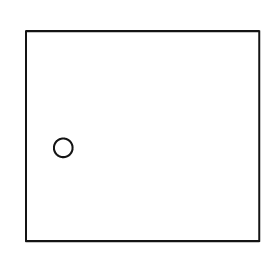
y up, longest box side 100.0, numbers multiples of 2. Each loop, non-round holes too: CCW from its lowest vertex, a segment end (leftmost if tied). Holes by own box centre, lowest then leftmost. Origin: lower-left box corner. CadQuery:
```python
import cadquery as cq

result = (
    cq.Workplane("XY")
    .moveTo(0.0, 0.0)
    .lineTo(100.0, 0.0)
    .lineTo(100.0, 90.0)
    .lineTo(0.0, 90.0)
    .close()
    .moveTo(16.0, 40.0)
    .circle(4.0)
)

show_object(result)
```